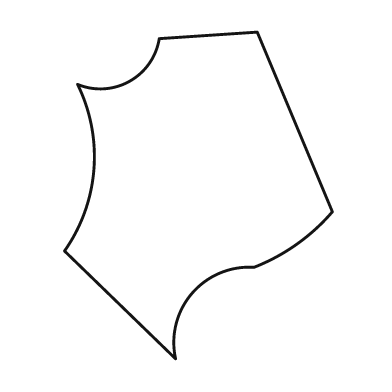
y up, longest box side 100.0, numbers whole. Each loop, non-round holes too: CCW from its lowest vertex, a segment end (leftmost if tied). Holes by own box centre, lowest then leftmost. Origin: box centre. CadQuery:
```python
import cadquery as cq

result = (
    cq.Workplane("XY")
    .moveTo(-7.0, -50.0)
    .threePointArc((-2.0, -30.0), (17.0, -22.0))
    .threePointArc((30.0, -15.0), (41.0, -5.0))
    .lineTo(18.0, 50.0)
    .lineTo(-12.0, 48.0)
    .threePointArc((-21.0, 35.0), (-37.0, 34.0))
    .threePointArc((-32.0, 8.0), (-41.0, -17.0))
    .close()
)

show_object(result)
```